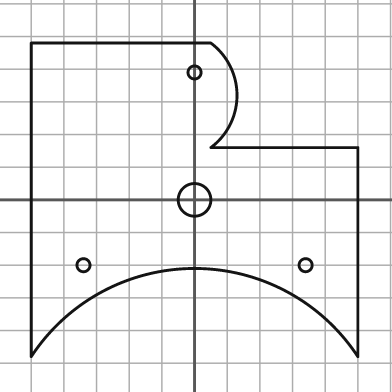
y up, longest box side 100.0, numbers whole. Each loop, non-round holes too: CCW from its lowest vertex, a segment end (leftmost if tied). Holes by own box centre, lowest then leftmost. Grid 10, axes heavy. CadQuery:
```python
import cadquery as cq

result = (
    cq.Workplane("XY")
    .moveTo(-50.0, -48.0)
    .threePointArc((0.0, -21.0), (50.0, -48.0))
    .lineTo(50.0, 16.0)
    .lineTo(5.0, 16.0)
    .threePointArc((13.0, 32.0), (5.0, 48.0))
    .lineTo(-50.0, 48.0)
    .close()
    .moveTo(-34.0, -20.0)
    .circle(2.0)
    .moveTo(34.0, -20.0)
    .circle(2.0)
    .moveTo(0.0, 0.0)
    .circle(5.0)
    .moveTo(0.0, 39.0)
    .circle(2.0)
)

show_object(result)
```